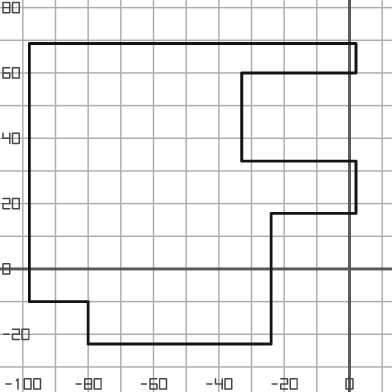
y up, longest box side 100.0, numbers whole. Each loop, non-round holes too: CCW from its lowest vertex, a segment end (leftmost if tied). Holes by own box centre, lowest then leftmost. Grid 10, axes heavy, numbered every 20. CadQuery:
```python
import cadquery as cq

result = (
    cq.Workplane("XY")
    .moveTo(-80.0, -23.0)
    .lineTo(-24.0, -23.0)
    .lineTo(-24.0, 17.0)
    .lineTo(2.0, 17.0)
    .lineTo(2.0, 33.0)
    .lineTo(-33.0, 33.0)
    .lineTo(-33.0, 60.0)
    .lineTo(2.0, 60.0)
    .lineTo(2.0, 69.0)
    .lineTo(-98.0, 69.0)
    .lineTo(-98.0, -10.0)
    .lineTo(-80.0, -10.0)
    .close()
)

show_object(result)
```